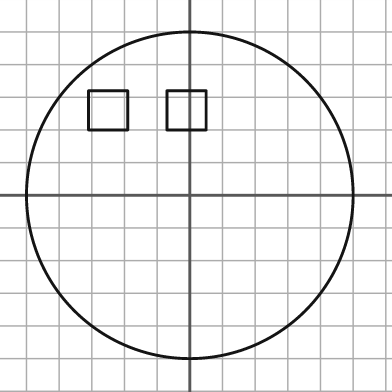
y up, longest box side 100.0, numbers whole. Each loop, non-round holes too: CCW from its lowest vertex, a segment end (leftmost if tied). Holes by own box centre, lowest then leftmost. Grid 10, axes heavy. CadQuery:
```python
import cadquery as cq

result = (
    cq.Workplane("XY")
    .moveTo(0.0, 0.0)
    .circle(50.0)
    .moveTo(-31.0, 20.0)
    .lineTo(-19.0, 20.0)
    .lineTo(-19.0, 32.0)
    .lineTo(-31.0, 32.0)
    .close()
    .moveTo(-7.0, 20.0)
    .lineTo(5.0, 20.0)
    .lineTo(5.0, 32.0)
    .lineTo(-7.0, 32.0)
    .close()
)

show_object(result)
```